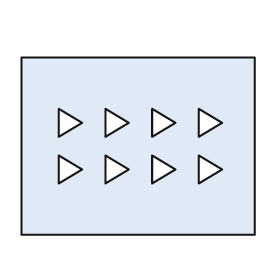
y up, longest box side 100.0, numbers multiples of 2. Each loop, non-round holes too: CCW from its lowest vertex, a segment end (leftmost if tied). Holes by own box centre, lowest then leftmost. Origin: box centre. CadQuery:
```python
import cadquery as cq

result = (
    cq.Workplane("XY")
    .moveTo(-50.0, -38.0)
    .lineTo(50.0, -38.0)
    .lineTo(50.0, 38.0)
    .lineTo(-50.0, 38.0)
    .close()
    .moveTo(-34.0, -16.0)
    .lineTo(-24.0, -10.0)
    .lineTo(-34.0, -4.0)
    .close()
    .moveTo(-14.0, -16.0)
    .lineTo(-4.0, -10.0)
    .lineTo(-14.0, -4.0)
    .close()
    .moveTo(6.0, -16.0)
    .lineTo(16.0, -10.0)
    .lineTo(6.0, -4.0)
    .close()
    .moveTo(26.0, -16.0)
    .lineTo(36.0, -10.0)
    .lineTo(26.0, -4.0)
    .close()
    .moveTo(-34.0, 4.0)
    .lineTo(-24.0, 10.0)
    .lineTo(-34.0, 16.0)
    .close()
    .moveTo(-14.0, 4.0)
    .lineTo(-4.0, 10.0)
    .lineTo(-14.0, 16.0)
    .close()
    .moveTo(6.0, 4.0)
    .lineTo(16.0, 10.0)
    .lineTo(6.0, 16.0)
    .close()
    .moveTo(26.0, 4.0)
    .lineTo(36.0, 10.0)
    .lineTo(26.0, 16.0)
    .close()
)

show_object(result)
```